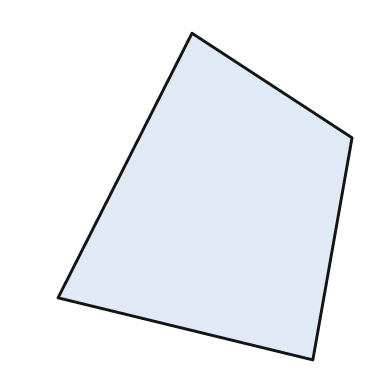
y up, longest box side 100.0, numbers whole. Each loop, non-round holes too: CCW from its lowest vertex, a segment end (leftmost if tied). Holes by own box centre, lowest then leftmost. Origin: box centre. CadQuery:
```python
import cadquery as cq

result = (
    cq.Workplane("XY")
    .moveTo(33.0, -50.0)
    .lineTo(45.0, 18.0)
    .lineTo(-4.0, 50.0)
    .lineTo(-45.0, -31.0)
    .close()
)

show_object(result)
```